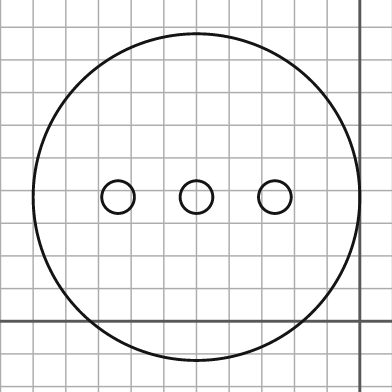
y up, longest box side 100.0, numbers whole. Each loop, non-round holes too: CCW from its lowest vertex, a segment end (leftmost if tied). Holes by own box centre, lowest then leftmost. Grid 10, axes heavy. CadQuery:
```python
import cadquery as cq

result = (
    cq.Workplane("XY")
    .moveTo(-50.0, 38.0)
    .circle(50.0)
    .moveTo(-74.0, 38.0)
    .circle(5.0)
    .moveTo(-50.0, 38.0)
    .circle(5.0)
    .moveTo(-26.0, 38.0)
    .circle(5.0)
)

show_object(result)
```